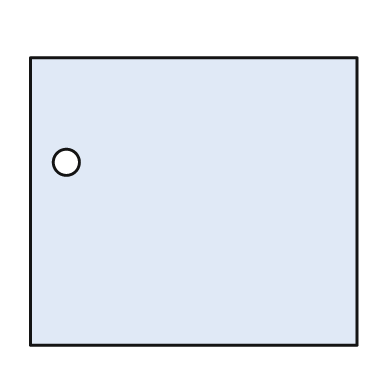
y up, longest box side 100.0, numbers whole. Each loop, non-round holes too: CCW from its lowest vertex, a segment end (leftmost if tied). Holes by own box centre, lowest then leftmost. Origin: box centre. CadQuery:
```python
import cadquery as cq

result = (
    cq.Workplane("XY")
    .moveTo(-50.0, -44.0)
    .lineTo(50.0, -44.0)
    .lineTo(50.0, 44.0)
    .lineTo(-50.0, 44.0)
    .close()
    .moveTo(-39.0, 12.0)
    .circle(4.0)
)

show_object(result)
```